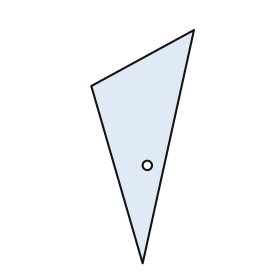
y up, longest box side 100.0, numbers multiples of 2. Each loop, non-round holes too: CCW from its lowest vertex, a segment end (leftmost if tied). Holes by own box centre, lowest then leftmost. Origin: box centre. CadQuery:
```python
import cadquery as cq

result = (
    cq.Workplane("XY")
    .moveTo(0.0, -50.0)
    .lineTo(22.0, 50.0)
    .lineTo(-22.0, 26.0)
    .close()
    .moveTo(2.0, -8.0)
    .circle(2.0)
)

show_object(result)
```